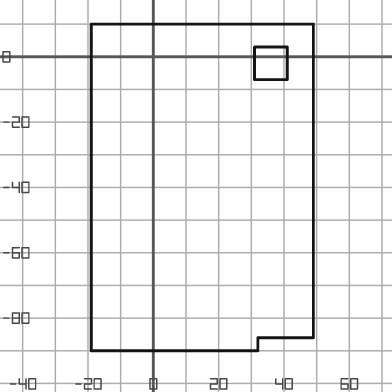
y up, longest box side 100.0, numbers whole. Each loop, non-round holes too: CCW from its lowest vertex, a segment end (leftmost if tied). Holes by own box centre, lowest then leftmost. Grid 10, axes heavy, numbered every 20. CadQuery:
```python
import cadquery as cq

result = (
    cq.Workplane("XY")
    .moveTo(-19.0, -90.0)
    .lineTo(32.0, -90.0)
    .lineTo(32.0, -86.0)
    .lineTo(49.0, -86.0)
    .lineTo(49.0, 10.0)
    .lineTo(-19.0, 10.0)
    .close()
    .moveTo(31.0, -7.0)
    .lineTo(41.0, -7.0)
    .lineTo(41.0, 3.0)
    .lineTo(31.0, 3.0)
    .close()
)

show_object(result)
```